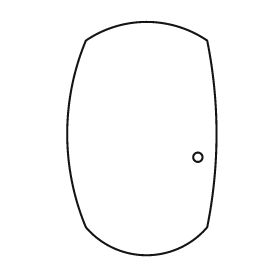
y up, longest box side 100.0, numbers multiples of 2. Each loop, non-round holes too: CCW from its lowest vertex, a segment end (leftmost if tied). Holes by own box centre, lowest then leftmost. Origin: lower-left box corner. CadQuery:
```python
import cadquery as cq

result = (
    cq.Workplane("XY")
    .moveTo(8.0, 12.0)
    .threePointArc((34.0, 0.0), (60.0, 12.0))
    .threePointArc((64.0, 52.0), (60.0, 92.0))
    .threePointArc((34.0, 100.0), (8.0, 92.0))
    .threePointArc((0.0, 52.0), (8.0, 12.0))
    .close()
    .moveTo(56.0, 42.0)
    .circle(2.0)
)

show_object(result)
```